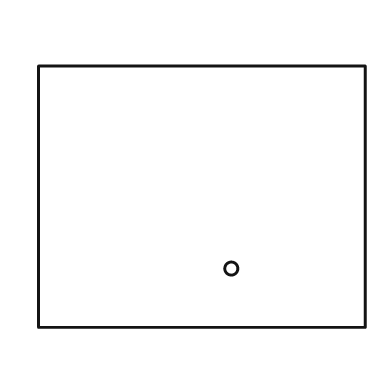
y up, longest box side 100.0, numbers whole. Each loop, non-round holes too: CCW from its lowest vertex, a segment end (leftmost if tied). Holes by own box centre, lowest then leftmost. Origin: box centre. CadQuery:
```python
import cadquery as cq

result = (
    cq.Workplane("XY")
    .moveTo(-50.0, -40.0)
    .lineTo(50.0, -40.0)
    .lineTo(50.0, 40.0)
    .lineTo(-50.0, 40.0)
    .close()
    .moveTo(9.0, -22.0)
    .circle(2.0)
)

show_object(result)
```